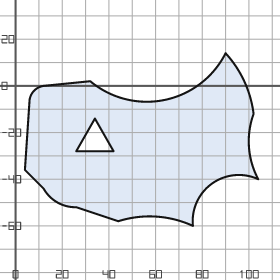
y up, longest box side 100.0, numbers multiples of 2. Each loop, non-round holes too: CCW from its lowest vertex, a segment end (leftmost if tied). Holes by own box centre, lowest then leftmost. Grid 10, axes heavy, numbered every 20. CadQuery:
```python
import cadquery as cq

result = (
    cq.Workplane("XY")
    .moveTo(76.0, -60.0)
    .threePointArc((84.0, -42.0), (104.0, -40.0))
    .threePointArc((100.0, -26.0), (102.0, -12.0))
    .threePointArc((98.0, 2.0), (90.0, 14.0))
    .threePointArc((64.0, -6.0), (32.0, 2.0))
    .lineTo(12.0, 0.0)
    .threePointArc((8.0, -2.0), (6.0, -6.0))
    .lineTo(4.0, -36.0)
    .lineTo(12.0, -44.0)
    .threePointArc((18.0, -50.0), (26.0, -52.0))
    .lineTo(44.0, -58.0)
    .threePointArc((60.0, -56.0), (76.0, -60.0))
    .close()
    .moveTo(26.0, -28.0)
    .lineTo(42.0, -28.0)
    .lineTo(34.0, -14.0)
    .close()
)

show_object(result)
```